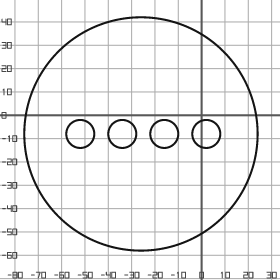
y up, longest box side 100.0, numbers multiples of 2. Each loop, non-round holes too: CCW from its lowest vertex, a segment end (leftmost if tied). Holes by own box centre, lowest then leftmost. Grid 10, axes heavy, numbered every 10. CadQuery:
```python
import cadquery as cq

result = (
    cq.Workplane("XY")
    .moveTo(-26.0, -8.0)
    .circle(50.0)
    .moveTo(-52.0, -8.0)
    .circle(6.0)
    .moveTo(-34.0, -8.0)
    .circle(6.0)
    .moveTo(-16.0, -8.0)
    .circle(6.0)
    .moveTo(2.0, -8.0)
    .circle(6.0)
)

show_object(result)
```